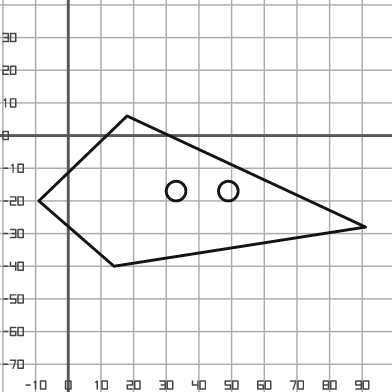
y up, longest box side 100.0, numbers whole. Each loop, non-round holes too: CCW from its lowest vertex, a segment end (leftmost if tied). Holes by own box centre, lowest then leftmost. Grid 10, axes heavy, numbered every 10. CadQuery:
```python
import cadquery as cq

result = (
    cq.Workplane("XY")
    .moveTo(14.0, -40.0)
    .lineTo(91.0, -28.0)
    .lineTo(18.0, 6.0)
    .lineTo(-9.0, -20.0)
    .close()
    .moveTo(33.0, -17.0)
    .circle(3.0)
    .moveTo(49.0, -17.0)
    .circle(3.0)
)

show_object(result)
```